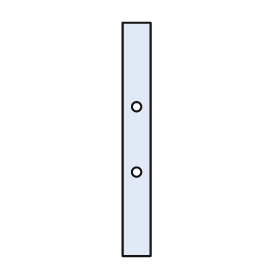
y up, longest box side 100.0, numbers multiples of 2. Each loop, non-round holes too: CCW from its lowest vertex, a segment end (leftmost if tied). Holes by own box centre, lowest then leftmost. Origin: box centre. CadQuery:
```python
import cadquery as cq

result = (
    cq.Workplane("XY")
    .moveTo(-6.0, -50.0)
    .lineTo(6.0, -50.0)
    .lineTo(6.0, 50.0)
    .lineTo(-6.0, 50.0)
    .close()
    .moveTo(0.0, -14.0)
    .circle(2.0)
    .moveTo(0.0, 14.0)
    .circle(2.0)
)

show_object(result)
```